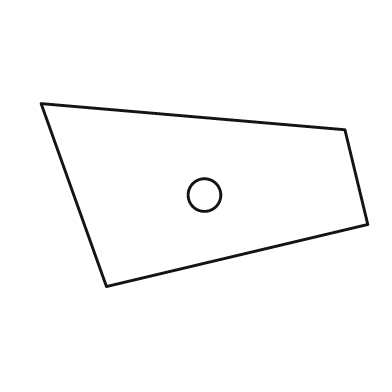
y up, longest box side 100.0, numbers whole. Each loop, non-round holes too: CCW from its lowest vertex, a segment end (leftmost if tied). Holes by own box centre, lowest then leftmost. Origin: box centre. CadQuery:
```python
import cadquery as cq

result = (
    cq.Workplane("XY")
    .moveTo(-30.0, -28.0)
    .lineTo(50.0, -9.0)
    .lineTo(43.0, 20.0)
    .lineTo(-50.0, 28.0)
    .close()
    .moveTo(0.0, 0.0)
    .circle(5.0)
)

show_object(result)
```